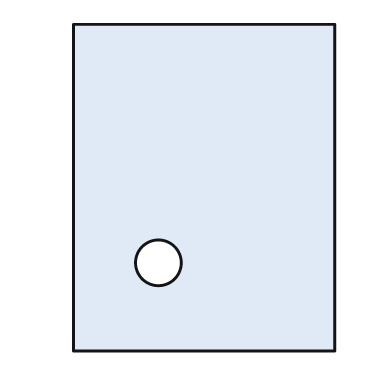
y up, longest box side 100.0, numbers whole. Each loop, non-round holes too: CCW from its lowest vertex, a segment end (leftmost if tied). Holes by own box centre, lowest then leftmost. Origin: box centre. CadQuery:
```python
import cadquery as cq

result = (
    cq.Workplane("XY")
    .moveTo(-40.0, -50.0)
    .lineTo(40.0, -50.0)
    .lineTo(40.0, 50.0)
    .lineTo(-40.0, 50.0)
    .close()
    .moveTo(-14.0, -23.0)
    .circle(7.0)
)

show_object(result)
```